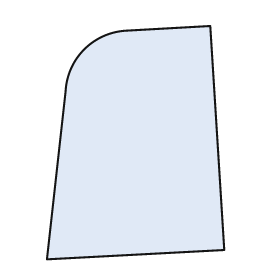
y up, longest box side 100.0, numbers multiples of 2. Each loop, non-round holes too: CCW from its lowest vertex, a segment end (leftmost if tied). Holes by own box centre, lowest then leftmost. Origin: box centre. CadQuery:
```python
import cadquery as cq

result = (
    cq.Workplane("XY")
    .moveTo(-38.0, -50.0)
    .lineTo(38.0, -46.0)
    .lineTo(32.0, 50.0)
    .lineTo(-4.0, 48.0)
    .threePointArc((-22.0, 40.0), (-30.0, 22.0))
    .close()
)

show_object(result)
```